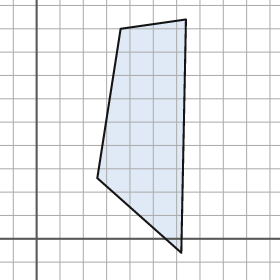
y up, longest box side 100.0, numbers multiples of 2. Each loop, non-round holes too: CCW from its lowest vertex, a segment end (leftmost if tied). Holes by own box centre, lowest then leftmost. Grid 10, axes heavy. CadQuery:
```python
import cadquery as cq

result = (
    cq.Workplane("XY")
    .moveTo(62.0, -6.0)
    .lineTo(64.0, 94.0)
    .lineTo(36.0, 90.0)
    .lineTo(26.0, 26.0)
    .close()
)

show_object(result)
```